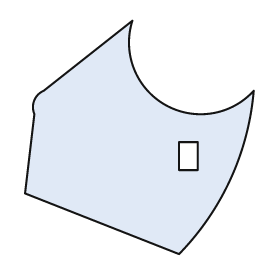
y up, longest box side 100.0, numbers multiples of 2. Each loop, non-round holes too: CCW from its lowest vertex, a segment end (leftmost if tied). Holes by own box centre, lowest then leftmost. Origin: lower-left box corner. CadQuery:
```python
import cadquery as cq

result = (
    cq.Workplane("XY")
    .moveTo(66.0, 0.0)
    .threePointArc((88.0, 32.0), (98.0, 70.0))
    .threePointArc((60.0, 64.0), (46.0, 100.0))
    .lineTo(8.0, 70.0)
    .threePointArc((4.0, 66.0), (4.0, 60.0))
    .lineTo(0.0, 26.0)
    .close()
    .moveTo(66.0, 36.0)
    .lineTo(74.0, 36.0)
    .lineTo(74.0, 48.0)
    .lineTo(66.0, 48.0)
    .close()
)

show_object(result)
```